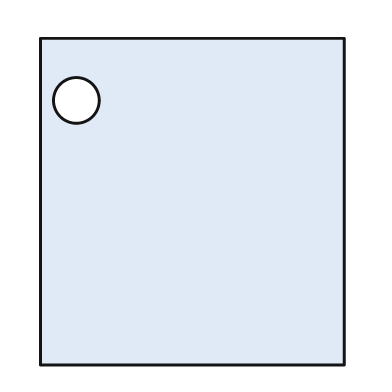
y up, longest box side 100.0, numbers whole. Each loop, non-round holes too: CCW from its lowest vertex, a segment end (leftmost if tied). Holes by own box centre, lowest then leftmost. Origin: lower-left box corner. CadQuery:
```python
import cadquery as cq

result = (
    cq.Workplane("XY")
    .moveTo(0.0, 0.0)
    .lineTo(93.0, 0.0)
    .lineTo(93.0, 100.0)
    .lineTo(0.0, 100.0)
    .close()
    .moveTo(11.0, 81.0)
    .circle(7.0)
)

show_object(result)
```